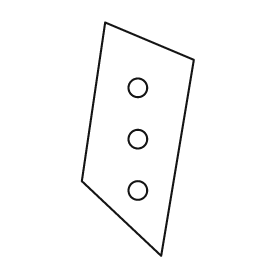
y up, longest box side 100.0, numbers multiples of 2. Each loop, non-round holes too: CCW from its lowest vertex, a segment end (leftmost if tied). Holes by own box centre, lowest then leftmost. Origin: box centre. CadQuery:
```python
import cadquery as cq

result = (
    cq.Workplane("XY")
    .moveTo(10.0, -50.0)
    .lineTo(24.0, 34.0)
    .lineTo(-14.0, 50.0)
    .lineTo(-24.0, -18.0)
    .close()
    .moveTo(0.0, -22.0)
    .circle(4.0)
    .moveTo(0.0, 0.0)
    .circle(4.0)
    .moveTo(0.0, 22.0)
    .circle(4.0)
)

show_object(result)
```